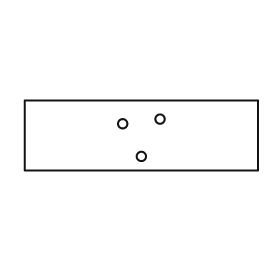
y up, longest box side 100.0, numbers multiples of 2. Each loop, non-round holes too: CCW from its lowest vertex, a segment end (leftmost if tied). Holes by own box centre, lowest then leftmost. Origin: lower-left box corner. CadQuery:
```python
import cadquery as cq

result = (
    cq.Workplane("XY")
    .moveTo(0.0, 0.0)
    .lineTo(100.0, 0.0)
    .lineTo(100.0, 30.0)
    .lineTo(0.0, 30.0)
    .close()
    .moveTo(50.0, 6.0)
    .circle(2.0)
    .moveTo(42.0, 20.0)
    .circle(2.0)
    .moveTo(58.0, 22.0)
    .circle(2.0)
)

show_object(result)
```